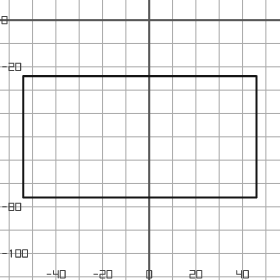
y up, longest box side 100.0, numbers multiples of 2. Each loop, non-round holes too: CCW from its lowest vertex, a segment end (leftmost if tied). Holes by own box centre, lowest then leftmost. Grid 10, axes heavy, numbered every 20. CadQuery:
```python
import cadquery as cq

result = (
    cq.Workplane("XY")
    .moveTo(-54.0, -76.0)
    .lineTo(46.0, -76.0)
    .lineTo(46.0, -24.0)
    .lineTo(-54.0, -24.0)
    .close()
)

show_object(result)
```